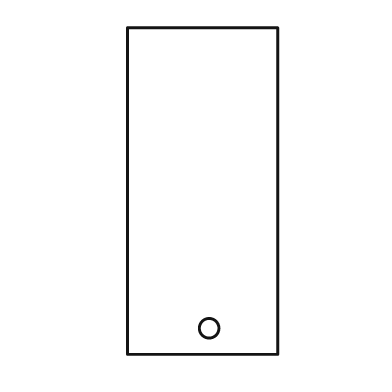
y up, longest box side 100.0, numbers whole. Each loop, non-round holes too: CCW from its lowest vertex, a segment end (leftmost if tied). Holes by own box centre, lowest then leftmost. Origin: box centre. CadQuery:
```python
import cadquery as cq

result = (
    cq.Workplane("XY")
    .moveTo(-23.0, -50.0)
    .lineTo(23.0, -50.0)
    .lineTo(23.0, 50.0)
    .lineTo(-23.0, 50.0)
    .close()
    .moveTo(2.0, -42.0)
    .circle(3.0)
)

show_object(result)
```